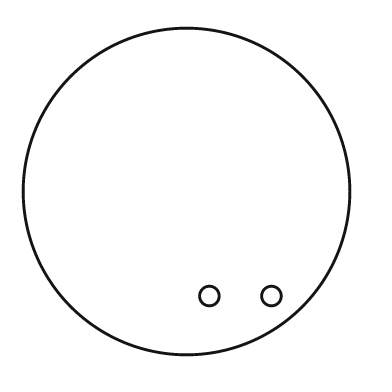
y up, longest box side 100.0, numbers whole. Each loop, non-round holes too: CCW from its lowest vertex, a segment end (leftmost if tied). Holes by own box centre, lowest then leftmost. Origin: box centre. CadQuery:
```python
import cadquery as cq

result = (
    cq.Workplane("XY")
    .moveTo(0.0, 0.0)
    .circle(50.0)
    .moveTo(7.0, -32.0)
    .circle(3.0)
    .moveTo(26.0, -32.0)
    .circle(3.0)
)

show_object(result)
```